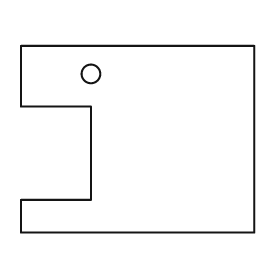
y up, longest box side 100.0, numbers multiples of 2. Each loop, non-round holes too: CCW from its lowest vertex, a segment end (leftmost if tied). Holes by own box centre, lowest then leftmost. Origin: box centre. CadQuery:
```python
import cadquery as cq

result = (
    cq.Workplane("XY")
    .moveTo(-50.0, -40.0)
    .lineTo(50.0, -40.0)
    .lineTo(50.0, 40.0)
    .lineTo(-50.0, 40.0)
    .lineTo(-50.0, 14.0)
    .lineTo(-20.0, 14.0)
    .lineTo(-20.0, -26.0)
    .lineTo(-50.0, -26.0)
    .close()
    .moveTo(-20.0, 28.0)
    .circle(4.0)
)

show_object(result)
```